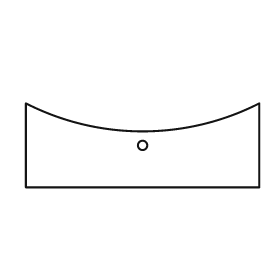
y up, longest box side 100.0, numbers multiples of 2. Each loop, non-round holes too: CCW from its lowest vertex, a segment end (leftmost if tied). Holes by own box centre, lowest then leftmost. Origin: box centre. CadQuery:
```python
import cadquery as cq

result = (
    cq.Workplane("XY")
    .moveTo(-50.0, -18.0)
    .lineTo(50.0, -18.0)
    .lineTo(50.0, 18.0)
    .threePointArc((0.0, 6.0), (-50.0, 18.0))
    .close()
    .moveTo(0.0, 0.0)
    .circle(2.0)
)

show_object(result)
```